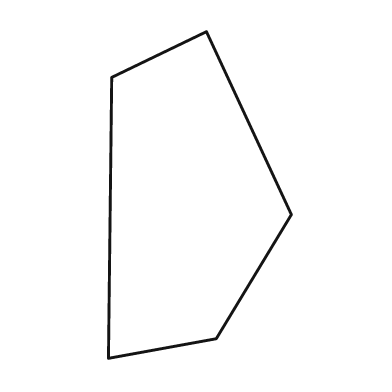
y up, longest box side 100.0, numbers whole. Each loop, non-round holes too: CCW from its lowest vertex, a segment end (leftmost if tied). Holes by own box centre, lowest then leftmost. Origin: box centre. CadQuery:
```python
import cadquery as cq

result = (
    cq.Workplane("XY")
    .moveTo(-28.0, -50.0)
    .lineTo(5.0, -44.0)
    .lineTo(28.0, -6.0)
    .lineTo(2.0, 50.0)
    .lineTo(-27.0, 36.0)
    .close()
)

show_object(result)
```